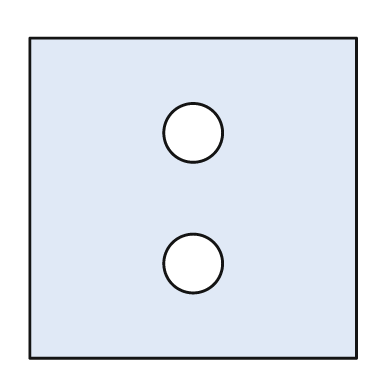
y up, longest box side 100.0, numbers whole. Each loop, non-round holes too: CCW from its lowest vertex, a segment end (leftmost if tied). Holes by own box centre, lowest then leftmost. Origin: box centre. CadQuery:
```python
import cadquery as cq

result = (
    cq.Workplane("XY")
    .moveTo(-50.0, -49.0)
    .lineTo(50.0, -49.0)
    .lineTo(50.0, 49.0)
    .lineTo(-50.0, 49.0)
    .close()
    .moveTo(0.0, -20.0)
    .circle(9.0)
    .moveTo(0.0, 20.0)
    .circle(9.0)
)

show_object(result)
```